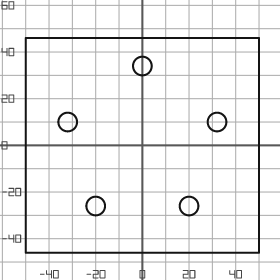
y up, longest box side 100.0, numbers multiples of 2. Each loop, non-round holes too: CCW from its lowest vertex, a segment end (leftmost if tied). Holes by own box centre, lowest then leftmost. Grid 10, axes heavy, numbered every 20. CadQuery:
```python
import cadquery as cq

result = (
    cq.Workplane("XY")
    .moveTo(-50.0, -46.0)
    .lineTo(50.0, -46.0)
    .lineTo(50.0, 46.0)
    .lineTo(-50.0, 46.0)
    .close()
    .moveTo(-20.0, -26.0)
    .circle(4.0)
    .moveTo(20.0, -26.0)
    .circle(4.0)
    .moveTo(-32.0, 10.0)
    .circle(4.0)
    .moveTo(32.0, 10.0)
    .circle(4.0)
    .moveTo(0.0, 34.0)
    .circle(4.0)
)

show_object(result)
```